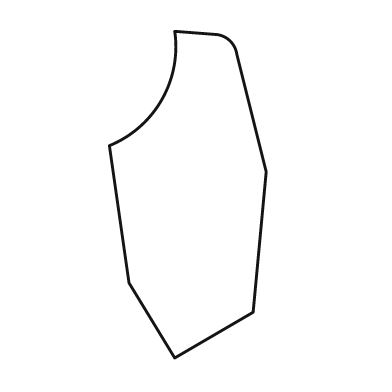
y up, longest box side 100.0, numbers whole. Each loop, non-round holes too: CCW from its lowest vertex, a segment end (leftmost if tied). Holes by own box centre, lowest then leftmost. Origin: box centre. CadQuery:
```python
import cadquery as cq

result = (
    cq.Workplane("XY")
    .moveTo(-4.0, -50.0)
    .lineTo(20.0, -36.0)
    .lineTo(24.0, 7.0)
    .lineTo(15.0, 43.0)
    .threePointArc((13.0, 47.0), (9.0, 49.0))
    .lineTo(-4.0, 50.0)
    .threePointArc((-8.0, 29.0), (-24.0, 15.0))
    .lineTo(-18.0, -27.0)
    .close()
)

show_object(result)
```